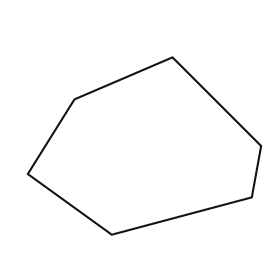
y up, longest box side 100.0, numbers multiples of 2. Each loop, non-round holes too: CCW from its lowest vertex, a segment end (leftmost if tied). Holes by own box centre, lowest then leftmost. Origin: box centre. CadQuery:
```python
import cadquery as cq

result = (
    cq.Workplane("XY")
    .moveTo(-14.0, -38.0)
    .lineTo(46.0, -22.0)
    .lineTo(50.0, 0.0)
    .lineTo(12.0, 38.0)
    .lineTo(-30.0, 20.0)
    .lineTo(-50.0, -12.0)
    .close()
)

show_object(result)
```